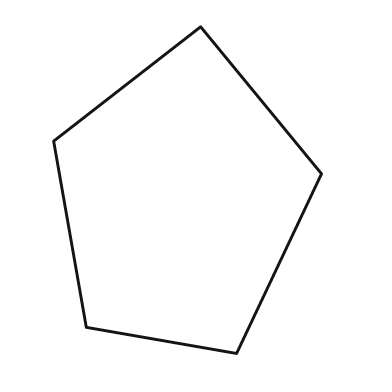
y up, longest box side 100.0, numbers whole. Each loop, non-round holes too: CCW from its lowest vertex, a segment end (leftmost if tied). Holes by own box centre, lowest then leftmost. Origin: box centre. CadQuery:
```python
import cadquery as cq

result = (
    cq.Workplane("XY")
    .moveTo(15.0, -50.0)
    .lineTo(41.0, 5.0)
    .lineTo(4.0, 50.0)
    .lineTo(-41.0, 15.0)
    .lineTo(-31.0, -42.0)
    .close()
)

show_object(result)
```